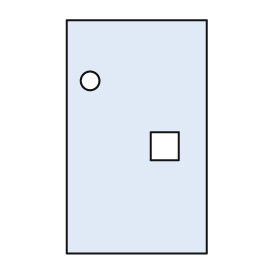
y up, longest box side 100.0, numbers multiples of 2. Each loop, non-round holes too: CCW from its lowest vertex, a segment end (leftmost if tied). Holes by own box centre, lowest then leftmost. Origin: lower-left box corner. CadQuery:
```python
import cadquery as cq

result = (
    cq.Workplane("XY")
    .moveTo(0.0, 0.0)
    .lineTo(60.0, 0.0)
    .lineTo(60.0, 100.0)
    .lineTo(0.0, 100.0)
    .close()
    .moveTo(36.0, 40.0)
    .lineTo(48.0, 40.0)
    .lineTo(48.0, 52.0)
    .lineTo(36.0, 52.0)
    .close()
    .moveTo(10.0, 74.0)
    .circle(4.0)
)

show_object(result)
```